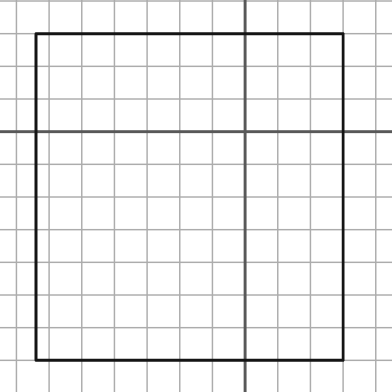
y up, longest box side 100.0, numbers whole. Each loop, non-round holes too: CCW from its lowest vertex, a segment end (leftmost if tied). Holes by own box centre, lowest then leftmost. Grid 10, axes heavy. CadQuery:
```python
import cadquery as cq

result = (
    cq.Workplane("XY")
    .moveTo(-64.0, -70.0)
    .lineTo(30.0, -70.0)
    .lineTo(30.0, 30.0)
    .lineTo(-64.0, 30.0)
    .close()
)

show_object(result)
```